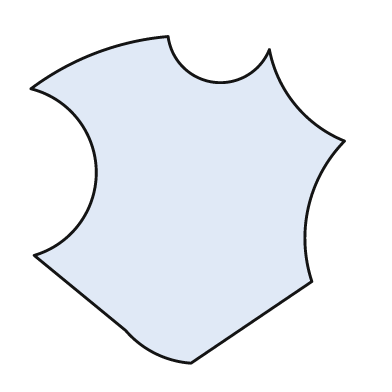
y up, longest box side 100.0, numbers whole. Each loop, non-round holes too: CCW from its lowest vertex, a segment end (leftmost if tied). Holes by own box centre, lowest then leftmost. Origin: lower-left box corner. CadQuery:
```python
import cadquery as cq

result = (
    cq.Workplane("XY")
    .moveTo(49.0, 0.0)
    .lineTo(86.0, 25.0)
    .threePointArc((85.0, 48.0), (96.0, 68.0))
    .threePointArc((81.0, 79.0), (73.0, 96.0))
    .threePointArc((56.0, 86.0), (42.0, 100.0))
    .threePointArc((20.0, 95.0), (0.0, 84.0))
    .threePointArc((20.0, 59.0), (1.0, 33.0))
    .lineTo(29.0, 10.0)
    .threePointArc((38.0, 3.0), (49.0, 0.0))
    .close()
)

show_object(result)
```